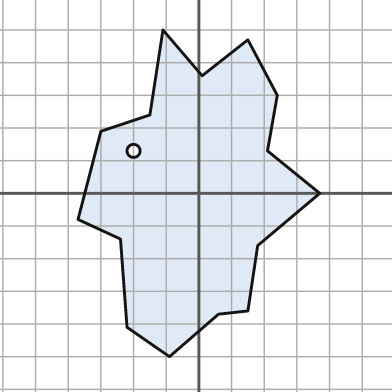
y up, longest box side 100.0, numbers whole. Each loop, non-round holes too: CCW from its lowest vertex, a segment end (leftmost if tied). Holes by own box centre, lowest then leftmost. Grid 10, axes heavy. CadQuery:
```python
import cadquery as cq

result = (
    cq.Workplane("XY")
    .moveTo(-9.0, -50.0)
    .lineTo(6.0, -37.0)
    .lineTo(15.0, -36.0)
    .lineTo(18.0, -16.0)
    .lineTo(37.0, 0.0)
    .lineTo(21.0, 13.0)
    .lineTo(24.0, 30.0)
    .lineTo(15.0, 47.0)
    .lineTo(1.0, 36.0)
    .lineTo(-11.0, 50.0)
    .lineTo(-15.0, 24.0)
    .lineTo(-30.0, 19.0)
    .lineTo(-37.0, -8.0)
    .lineTo(-24.0, -14.0)
    .lineTo(-22.0, -41.0)
    .close()
    .moveTo(-20.0, 13.0)
    .circle(2.0)
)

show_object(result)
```